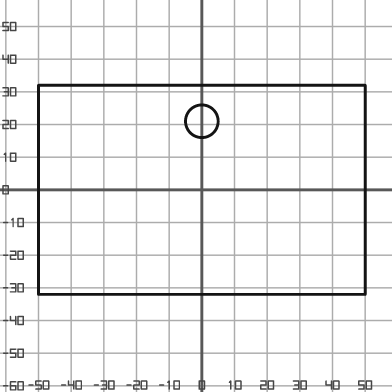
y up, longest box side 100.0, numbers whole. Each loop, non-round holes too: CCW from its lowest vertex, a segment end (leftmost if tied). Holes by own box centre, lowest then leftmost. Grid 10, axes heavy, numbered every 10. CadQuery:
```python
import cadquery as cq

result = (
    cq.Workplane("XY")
    .moveTo(-50.0, -32.0)
    .lineTo(50.0, -32.0)
    .lineTo(50.0, 32.0)
    .lineTo(-50.0, 32.0)
    .close()
    .moveTo(0.0, 21.0)
    .circle(5.0)
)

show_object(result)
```